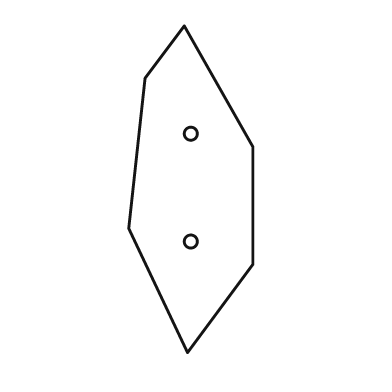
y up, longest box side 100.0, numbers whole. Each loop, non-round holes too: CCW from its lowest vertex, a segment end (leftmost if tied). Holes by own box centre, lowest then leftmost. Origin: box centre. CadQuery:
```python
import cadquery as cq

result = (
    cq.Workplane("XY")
    .moveTo(-1.0, -50.0)
    .lineTo(19.0, -23.0)
    .lineTo(19.0, 13.0)
    .lineTo(-2.0, 50.0)
    .lineTo(-14.0, 34.0)
    .lineTo(-19.0, -12.0)
    .close()
    .moveTo(0.0, -16.0)
    .circle(2.0)
    .moveTo(0.0, 17.0)
    .circle(2.0)
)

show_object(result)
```